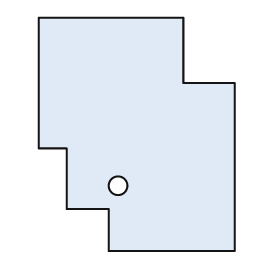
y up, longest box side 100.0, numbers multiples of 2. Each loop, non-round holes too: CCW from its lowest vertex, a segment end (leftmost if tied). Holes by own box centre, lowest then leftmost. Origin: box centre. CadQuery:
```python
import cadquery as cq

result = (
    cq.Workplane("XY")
    .moveTo(-12.0, -50.0)
    .lineTo(42.0, -50.0)
    .lineTo(42.0, 22.0)
    .lineTo(20.0, 22.0)
    .lineTo(20.0, 50.0)
    .lineTo(-42.0, 50.0)
    .lineTo(-42.0, -6.0)
    .lineTo(-30.0, -6.0)
    .lineTo(-30.0, -32.0)
    .lineTo(-12.0, -32.0)
    .close()
    .moveTo(-8.0, -22.0)
    .circle(4.0)
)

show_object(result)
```